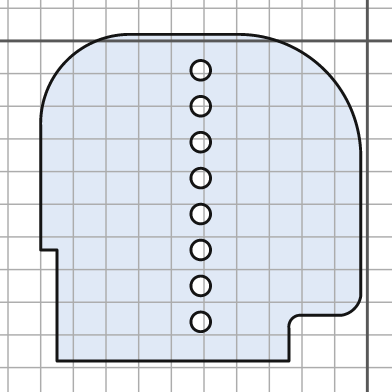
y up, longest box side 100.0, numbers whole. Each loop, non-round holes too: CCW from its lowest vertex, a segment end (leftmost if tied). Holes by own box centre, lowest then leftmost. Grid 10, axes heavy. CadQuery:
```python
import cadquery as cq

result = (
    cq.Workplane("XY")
    .moveTo(-95.0, -98.0)
    .lineTo(-24.0, -98.0)
    .lineTo(-24.0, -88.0)
    .threePointArc((-23.0, -85.0), (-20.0, -84.0))
    .lineTo(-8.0, -84.0)
    .threePointArc((-4.0, -82.0), (-2.0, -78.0))
    .lineTo(-2.0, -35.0)
    .threePointArc((-13.0, -9.0), (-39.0, 2.0))
    .lineTo(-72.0, 2.0)
    .threePointArc((-92.0, -6.0), (-100.0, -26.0))
    .lineTo(-100.0, -64.0)
    .lineTo(-95.0, -64.0)
    .close()
    .moveTo(-51.0, -86.0)
    .circle(3.0)
    .moveTo(-51.0, -75.0)
    .circle(3.0)
    .moveTo(-51.0, -64.0)
    .circle(3.0)
    .moveTo(-51.0, -53.0)
    .circle(3.0)
    .moveTo(-51.0, -42.0)
    .circle(3.0)
    .moveTo(-51.0, -31.0)
    .circle(3.0)
    .moveTo(-51.0, -20.0)
    .circle(3.0)
    .moveTo(-51.0, -9.0)
    .circle(3.0)
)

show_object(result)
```